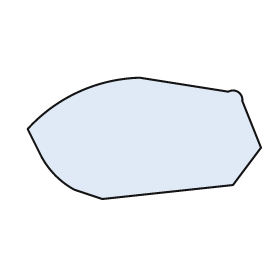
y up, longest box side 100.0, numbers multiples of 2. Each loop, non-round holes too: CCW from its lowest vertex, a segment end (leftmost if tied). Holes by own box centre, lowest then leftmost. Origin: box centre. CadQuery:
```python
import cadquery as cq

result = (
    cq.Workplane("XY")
    .moveTo(-18.0, -26.0)
    .lineTo(38.0, -20.0)
    .lineTo(50.0, -4.0)
    .lineTo(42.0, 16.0)
    .threePointArc((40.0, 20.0), (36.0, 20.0))
    .lineTo(-2.0, 26.0)
    .threePointArc((-28.0, 20.0), (-50.0, 4.0))
    .lineTo(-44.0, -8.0)
    .threePointArc((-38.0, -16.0), (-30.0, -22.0))
    .close()
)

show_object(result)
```